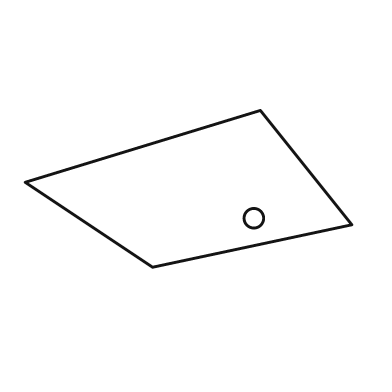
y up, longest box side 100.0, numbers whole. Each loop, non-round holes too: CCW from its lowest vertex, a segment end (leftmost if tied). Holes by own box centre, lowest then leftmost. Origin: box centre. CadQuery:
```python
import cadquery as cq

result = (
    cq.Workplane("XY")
    .moveTo(-11.0, -24.0)
    .lineTo(50.0, -11.0)
    .lineTo(22.0, 24.0)
    .lineTo(-50.0, 2.0)
    .close()
    .moveTo(20.0, -9.0)
    .circle(3.0)
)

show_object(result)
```